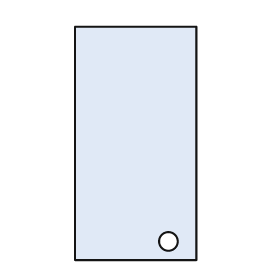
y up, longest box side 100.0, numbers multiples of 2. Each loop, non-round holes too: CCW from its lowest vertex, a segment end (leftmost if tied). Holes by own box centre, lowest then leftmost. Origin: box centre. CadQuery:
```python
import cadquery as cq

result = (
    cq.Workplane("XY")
    .moveTo(-26.0, -50.0)
    .lineTo(26.0, -50.0)
    .lineTo(26.0, 50.0)
    .lineTo(-26.0, 50.0)
    .close()
    .moveTo(14.0, -42.0)
    .circle(4.0)
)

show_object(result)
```